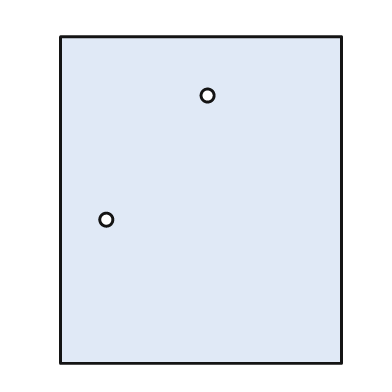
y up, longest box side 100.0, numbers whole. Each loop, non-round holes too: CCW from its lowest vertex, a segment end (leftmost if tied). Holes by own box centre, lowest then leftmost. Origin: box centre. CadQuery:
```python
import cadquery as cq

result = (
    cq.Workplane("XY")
    .moveTo(-43.0, -50.0)
    .lineTo(43.0, -50.0)
    .lineTo(43.0, 50.0)
    .lineTo(-43.0, 50.0)
    .close()
    .moveTo(-29.0, -6.0)
    .circle(2.0)
    .moveTo(2.0, 32.0)
    .circle(2.0)
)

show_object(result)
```